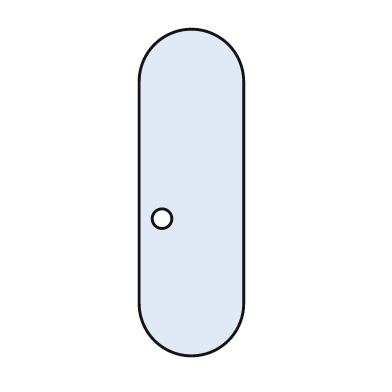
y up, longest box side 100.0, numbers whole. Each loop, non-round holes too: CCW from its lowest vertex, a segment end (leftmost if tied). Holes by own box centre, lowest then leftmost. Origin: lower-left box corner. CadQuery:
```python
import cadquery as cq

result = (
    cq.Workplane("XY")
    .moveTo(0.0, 16.0)
    .threePointArc((16.0, 0.0), (32.0, 16.0))
    .lineTo(32.0, 84.0)
    .threePointArc((16.0, 100.0), (0.0, 84.0))
    .close()
    .moveTo(7.0, 42.0)
    .circle(3.0)
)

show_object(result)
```